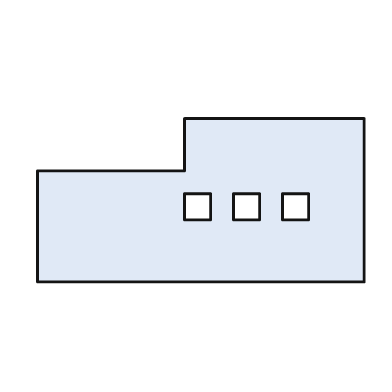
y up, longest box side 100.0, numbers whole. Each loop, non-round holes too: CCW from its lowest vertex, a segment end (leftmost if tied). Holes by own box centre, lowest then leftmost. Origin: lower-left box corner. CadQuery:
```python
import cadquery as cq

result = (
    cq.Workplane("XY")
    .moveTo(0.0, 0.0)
    .lineTo(100.0, 0.0)
    .lineTo(100.0, 50.0)
    .lineTo(45.0, 50.0)
    .lineTo(45.0, 34.0)
    .lineTo(0.0, 34.0)
    .close()
    .moveTo(45.0, 19.0)
    .lineTo(53.0, 19.0)
    .lineTo(53.0, 27.0)
    .lineTo(45.0, 27.0)
    .close()
    .moveTo(60.0, 19.0)
    .lineTo(68.0, 19.0)
    .lineTo(68.0, 27.0)
    .lineTo(60.0, 27.0)
    .close()
    .moveTo(75.0, 19.0)
    .lineTo(83.0, 19.0)
    .lineTo(83.0, 27.0)
    .lineTo(75.0, 27.0)
    .close()
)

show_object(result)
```